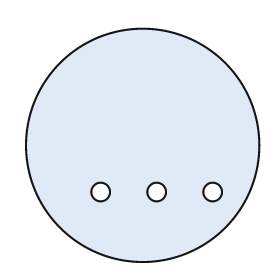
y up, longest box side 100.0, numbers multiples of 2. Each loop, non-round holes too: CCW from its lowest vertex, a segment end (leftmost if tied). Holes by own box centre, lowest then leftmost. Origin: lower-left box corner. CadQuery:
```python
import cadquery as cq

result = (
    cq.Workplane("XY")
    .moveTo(50.0, 50.0)
    .circle(50.0)
    .moveTo(32.0, 30.0)
    .circle(4.0)
    .moveTo(56.0, 30.0)
    .circle(4.0)
    .moveTo(80.0, 30.0)
    .circle(4.0)
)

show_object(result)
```